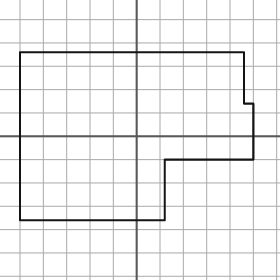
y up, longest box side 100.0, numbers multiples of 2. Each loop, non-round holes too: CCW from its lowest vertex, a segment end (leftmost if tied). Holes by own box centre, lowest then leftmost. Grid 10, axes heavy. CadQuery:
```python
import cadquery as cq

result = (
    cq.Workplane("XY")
    .moveTo(-50.0, -36.0)
    .lineTo(12.0, -36.0)
    .lineTo(12.0, -10.0)
    .lineTo(50.0, -10.0)
    .lineTo(50.0, 14.0)
    .lineTo(46.0, 14.0)
    .lineTo(46.0, 36.0)
    .lineTo(-50.0, 36.0)
    .close()
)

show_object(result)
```